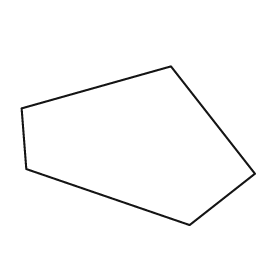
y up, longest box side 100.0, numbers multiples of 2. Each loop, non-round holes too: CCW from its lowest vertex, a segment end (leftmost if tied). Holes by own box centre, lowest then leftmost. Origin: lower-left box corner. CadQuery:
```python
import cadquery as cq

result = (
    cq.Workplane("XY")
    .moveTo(72.0, 0.0)
    .lineTo(100.0, 22.0)
    .lineTo(64.0, 68.0)
    .lineTo(0.0, 50.0)
    .lineTo(2.0, 24.0)
    .close()
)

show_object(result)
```